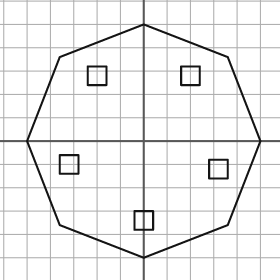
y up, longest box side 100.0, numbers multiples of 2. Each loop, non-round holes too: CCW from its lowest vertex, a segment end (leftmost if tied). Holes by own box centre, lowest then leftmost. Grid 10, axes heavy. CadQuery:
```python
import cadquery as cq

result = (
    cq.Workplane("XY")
    .moveTo(0.0, -50.0)
    .lineTo(36.0, -36.0)
    .lineTo(50.0, 0.0)
    .lineTo(36.0, 36.0)
    .lineTo(0.0, 50.0)
    .lineTo(-36.0, 36.0)
    .lineTo(-50.0, 0.0)
    .lineTo(-36.0, -36.0)
    .close()
    .moveTo(-4.0, -38.0)
    .lineTo(4.0, -38.0)
    .lineTo(4.0, -30.0)
    .lineTo(-4.0, -30.0)
    .close()
    .moveTo(28.0, -16.0)
    .lineTo(36.0, -16.0)
    .lineTo(36.0, -8.0)
    .lineTo(28.0, -8.0)
    .close()
    .moveTo(-36.0, -14.0)
    .lineTo(-28.0, -14.0)
    .lineTo(-28.0, -6.0)
    .lineTo(-36.0, -6.0)
    .close()
    .moveTo(-24.0, 24.0)
    .lineTo(-16.0, 24.0)
    .lineTo(-16.0, 32.0)
    .lineTo(-24.0, 32.0)
    .close()
    .moveTo(16.0, 24.0)
    .lineTo(24.0, 24.0)
    .lineTo(24.0, 32.0)
    .lineTo(16.0, 32.0)
    .close()
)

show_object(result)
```